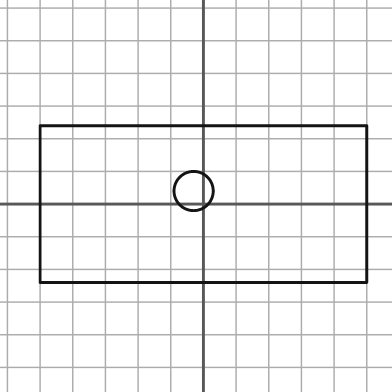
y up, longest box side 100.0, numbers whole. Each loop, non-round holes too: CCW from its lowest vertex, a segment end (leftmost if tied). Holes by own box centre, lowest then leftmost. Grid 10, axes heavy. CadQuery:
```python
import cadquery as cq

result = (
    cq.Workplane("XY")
    .moveTo(-50.0, -24.0)
    .lineTo(50.0, -24.0)
    .lineTo(50.0, 24.0)
    .lineTo(-50.0, 24.0)
    .close()
    .moveTo(-3.0, 4.0)
    .circle(6.0)
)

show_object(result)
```